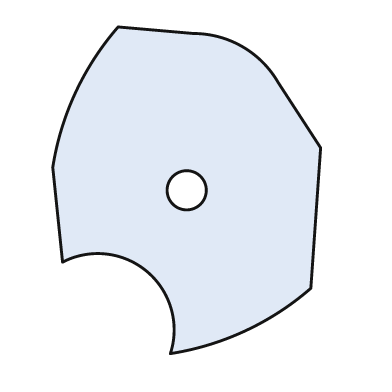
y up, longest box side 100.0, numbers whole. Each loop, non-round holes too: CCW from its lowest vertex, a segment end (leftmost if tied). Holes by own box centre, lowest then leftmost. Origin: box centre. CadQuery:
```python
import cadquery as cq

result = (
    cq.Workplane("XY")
    .moveTo(-5.0, -50.0)
    .threePointArc((18.0, -43.0), (38.0, -30.0))
    .lineTo(41.0, 13.0)
    .lineTo(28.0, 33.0)
    .threePointArc((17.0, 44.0), (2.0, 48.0))
    .lineTo(-21.0, 50.0)
    .threePointArc((-34.0, 30.0), (-41.0, 7.0))
    .lineTo(-38.0, -22.0)
    .threePointArc((-12.0, -25.0), (-5.0, -50.0))
    .close()
    .moveTo(0.0, 0.0)
    .circle(6.0)
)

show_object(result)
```